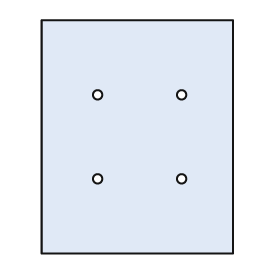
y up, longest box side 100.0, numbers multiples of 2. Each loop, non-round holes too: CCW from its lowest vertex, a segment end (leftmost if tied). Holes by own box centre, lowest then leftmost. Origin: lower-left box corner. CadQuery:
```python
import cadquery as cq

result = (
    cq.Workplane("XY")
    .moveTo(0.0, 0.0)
    .lineTo(82.0, 0.0)
    .lineTo(82.0, 100.0)
    .lineTo(0.0, 100.0)
    .close()
    .moveTo(24.0, 32.0)
    .circle(2.0)
    .moveTo(60.0, 32.0)
    .circle(2.0)
    .moveTo(24.0, 68.0)
    .circle(2.0)
    .moveTo(60.0, 68.0)
    .circle(2.0)
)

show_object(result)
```